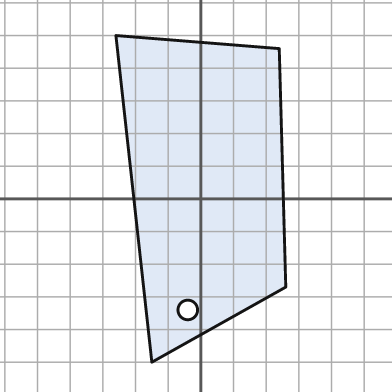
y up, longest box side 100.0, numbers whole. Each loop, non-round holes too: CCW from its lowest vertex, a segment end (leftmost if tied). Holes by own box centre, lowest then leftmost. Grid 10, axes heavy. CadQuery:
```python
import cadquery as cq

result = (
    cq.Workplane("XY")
    .moveTo(-15.0, -50.0)
    .lineTo(26.0, -27.0)
    .lineTo(24.0, 46.0)
    .lineTo(-26.0, 50.0)
    .close()
    .moveTo(-4.0, -34.0)
    .circle(3.0)
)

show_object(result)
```